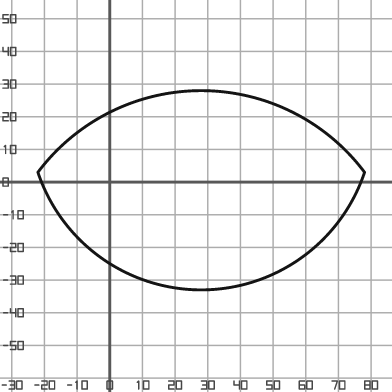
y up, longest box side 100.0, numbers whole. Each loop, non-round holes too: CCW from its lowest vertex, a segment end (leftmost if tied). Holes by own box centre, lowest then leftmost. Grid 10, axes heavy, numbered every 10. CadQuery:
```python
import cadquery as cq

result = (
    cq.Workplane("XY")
    .moveTo(-22.0, 3.0)
    .threePointArc((28.0, -33.0), (78.0, 3.0))
    .threePointArc((28.0, 28.0), (-22.0, 3.0))
    .close()
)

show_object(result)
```